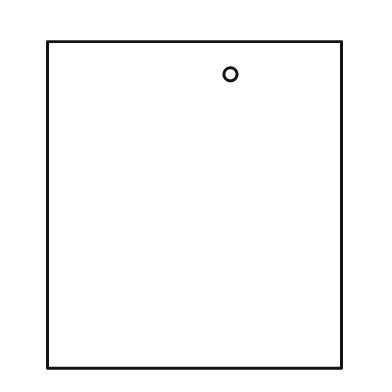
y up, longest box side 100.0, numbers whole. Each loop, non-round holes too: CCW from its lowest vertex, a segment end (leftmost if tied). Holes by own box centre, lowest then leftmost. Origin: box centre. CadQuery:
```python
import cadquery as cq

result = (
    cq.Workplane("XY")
    .moveTo(-45.0, -50.0)
    .lineTo(45.0, -50.0)
    .lineTo(45.0, 50.0)
    .lineTo(-45.0, 50.0)
    .close()
    .moveTo(11.0, 40.0)
    .circle(2.0)
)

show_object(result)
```